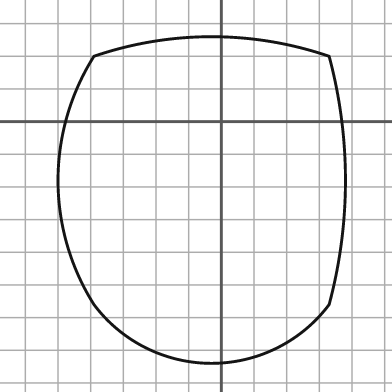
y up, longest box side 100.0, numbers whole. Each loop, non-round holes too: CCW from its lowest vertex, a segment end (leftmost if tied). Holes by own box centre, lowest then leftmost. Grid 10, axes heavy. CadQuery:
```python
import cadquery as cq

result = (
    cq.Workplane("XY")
    .moveTo(-39.0, -56.0)
    .threePointArc((-3.0, -74.0), (33.0, -56.0))
    .threePointArc((38.0, -18.0), (33.0, 20.0))
    .threePointArc((-3.0, 26.0), (-39.0, 20.0))
    .threePointArc((-50.0, -18.0), (-39.0, -56.0))
    .close()
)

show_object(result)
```